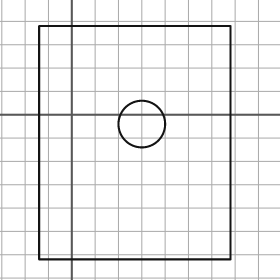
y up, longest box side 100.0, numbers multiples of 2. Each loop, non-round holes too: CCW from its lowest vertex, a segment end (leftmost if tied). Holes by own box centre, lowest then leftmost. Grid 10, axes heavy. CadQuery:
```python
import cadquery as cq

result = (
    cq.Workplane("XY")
    .moveTo(-14.0, -62.0)
    .lineTo(68.0, -62.0)
    .lineTo(68.0, 38.0)
    .lineTo(-14.0, 38.0)
    .close()
    .moveTo(30.0, -4.0)
    .circle(10.0)
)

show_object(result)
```